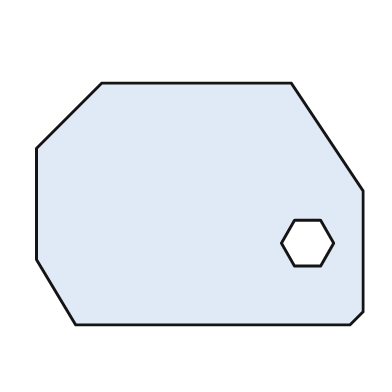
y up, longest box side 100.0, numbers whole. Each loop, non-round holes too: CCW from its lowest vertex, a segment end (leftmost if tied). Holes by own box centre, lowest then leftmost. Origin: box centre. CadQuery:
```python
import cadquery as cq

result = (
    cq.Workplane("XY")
    .moveTo(-38.0, -37.0)
    .lineTo(46.0, -37.0)
    .lineTo(50.0, -33.0)
    .lineTo(50.0, 4.0)
    .lineTo(28.0, 37.0)
    .lineTo(-30.0, 37.0)
    .lineTo(-50.0, 17.0)
    .lineTo(-50.0, -17.0)
    .close()
    .moveTo(29.0, -19.0)
    .lineTo(37.0, -19.0)
    .lineTo(41.0, -12.0)
    .lineTo(37.0, -5.0)
    .lineTo(29.0, -5.0)
    .lineTo(25.0, -12.0)
    .close()
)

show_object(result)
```